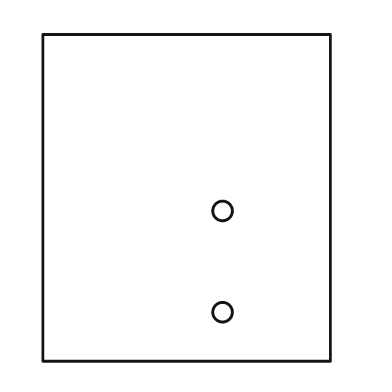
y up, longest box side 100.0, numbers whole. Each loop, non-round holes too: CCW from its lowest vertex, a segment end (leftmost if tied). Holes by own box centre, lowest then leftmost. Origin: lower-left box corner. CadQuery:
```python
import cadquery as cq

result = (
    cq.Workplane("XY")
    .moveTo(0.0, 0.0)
    .lineTo(88.0, 0.0)
    .lineTo(88.0, 100.0)
    .lineTo(0.0, 100.0)
    .close()
    .moveTo(55.0, 15.0)
    .circle(3.0)
    .moveTo(55.0, 46.0)
    .circle(3.0)
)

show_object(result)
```